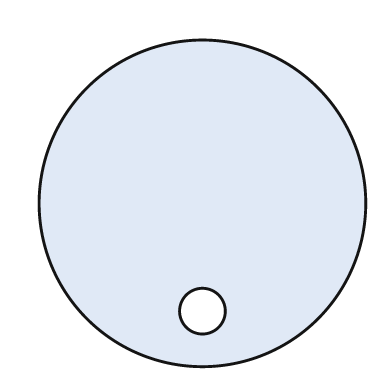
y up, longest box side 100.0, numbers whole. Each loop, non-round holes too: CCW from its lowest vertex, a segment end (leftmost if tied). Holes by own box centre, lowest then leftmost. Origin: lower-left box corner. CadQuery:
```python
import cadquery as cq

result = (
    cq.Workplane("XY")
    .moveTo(50.0, 50.0)
    .circle(50.0)
    .moveTo(50.0, 17.0)
    .circle(7.0)
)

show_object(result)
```